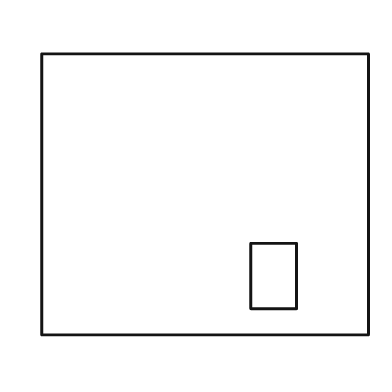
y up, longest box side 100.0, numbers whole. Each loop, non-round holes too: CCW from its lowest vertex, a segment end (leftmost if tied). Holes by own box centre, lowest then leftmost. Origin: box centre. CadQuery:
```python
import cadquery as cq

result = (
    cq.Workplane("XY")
    .moveTo(-50.0, -43.0)
    .lineTo(50.0, -43.0)
    .lineTo(50.0, 43.0)
    .lineTo(-50.0, 43.0)
    .close()
    .moveTo(14.0, -35.0)
    .lineTo(28.0, -35.0)
    .lineTo(28.0, -15.0)
    .lineTo(14.0, -15.0)
    .close()
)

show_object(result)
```